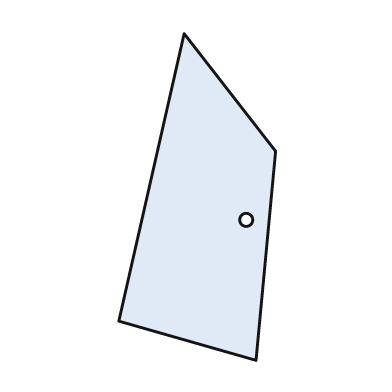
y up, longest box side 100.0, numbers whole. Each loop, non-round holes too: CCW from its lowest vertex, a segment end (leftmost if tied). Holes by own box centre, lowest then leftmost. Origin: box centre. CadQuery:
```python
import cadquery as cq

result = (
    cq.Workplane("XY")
    .moveTo(18.0, -50.0)
    .lineTo(24.0, 14.0)
    .lineTo(-4.0, 50.0)
    .lineTo(-24.0, -38.0)
    .close()
    .moveTo(15.0, -7.0)
    .circle(2.0)
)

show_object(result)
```